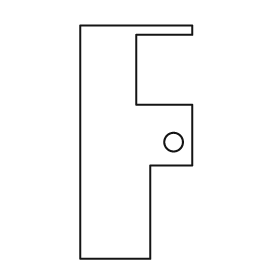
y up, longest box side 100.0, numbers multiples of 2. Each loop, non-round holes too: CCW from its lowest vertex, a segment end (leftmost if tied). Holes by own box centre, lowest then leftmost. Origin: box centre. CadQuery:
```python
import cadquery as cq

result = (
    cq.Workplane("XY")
    .moveTo(-24.0, -50.0)
    .lineTo(6.0, -50.0)
    .lineTo(6.0, -10.0)
    .lineTo(24.0, -10.0)
    .lineTo(24.0, 16.0)
    .lineTo(0.0, 16.0)
    .lineTo(0.0, 46.0)
    .lineTo(24.0, 46.0)
    .lineTo(24.0, 50.0)
    .lineTo(-24.0, 50.0)
    .close()
    .moveTo(16.0, 0.0)
    .circle(4.0)
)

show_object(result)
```